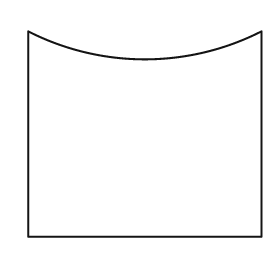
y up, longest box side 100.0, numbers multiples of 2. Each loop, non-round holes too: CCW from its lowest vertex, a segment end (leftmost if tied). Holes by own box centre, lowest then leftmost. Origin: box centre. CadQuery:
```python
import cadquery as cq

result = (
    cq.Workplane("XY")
    .moveTo(-50.0, -44.0)
    .lineTo(50.0, -44.0)
    .lineTo(50.0, 44.0)
    .threePointArc((0.0, 32.0), (-50.0, 44.0))
    .close()
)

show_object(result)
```